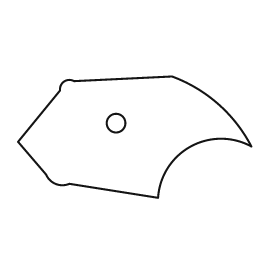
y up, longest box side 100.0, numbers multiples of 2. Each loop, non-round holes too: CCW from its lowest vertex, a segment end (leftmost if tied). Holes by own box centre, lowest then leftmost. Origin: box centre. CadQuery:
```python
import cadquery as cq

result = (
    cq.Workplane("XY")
    .moveTo(10.0, -26.0)
    .threePointArc((24.0, -4.0), (50.0, -4.0))
    .threePointArc((36.0, 14.0), (16.0, 26.0))
    .lineTo(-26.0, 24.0)
    .threePointArc((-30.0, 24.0), (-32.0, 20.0))
    .lineTo(-50.0, -2.0)
    .lineTo(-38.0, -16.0)
    .threePointArc((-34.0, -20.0), (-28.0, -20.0))
    .close()
    .moveTo(-8.0, 6.0)
    .circle(4.0)
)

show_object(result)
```